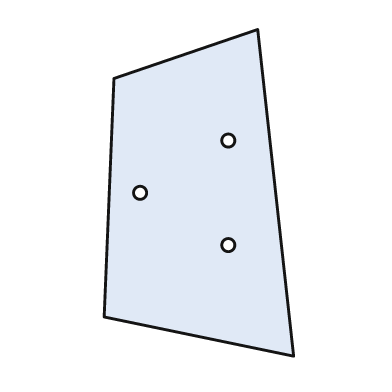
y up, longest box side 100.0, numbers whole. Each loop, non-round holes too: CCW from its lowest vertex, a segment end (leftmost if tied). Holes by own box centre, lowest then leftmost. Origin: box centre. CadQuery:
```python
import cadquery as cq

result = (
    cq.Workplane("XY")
    .moveTo(29.0, -50.0)
    .lineTo(18.0, 50.0)
    .lineTo(-26.0, 35.0)
    .lineTo(-29.0, -38.0)
    .close()
    .moveTo(9.0, -16.0)
    .circle(2.0)
    .moveTo(-18.0, 0.0)
    .circle(2.0)
    .moveTo(9.0, 16.0)
    .circle(2.0)
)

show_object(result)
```